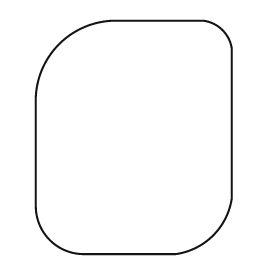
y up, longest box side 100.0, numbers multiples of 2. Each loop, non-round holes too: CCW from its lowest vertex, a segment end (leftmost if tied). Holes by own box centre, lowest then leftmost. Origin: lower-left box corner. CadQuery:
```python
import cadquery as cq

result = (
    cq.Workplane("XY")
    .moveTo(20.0, 0.0)
    .lineTo(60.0, 0.0)
    .threePointArc((76.0, 8.0), (84.0, 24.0))
    .lineTo(84.0, 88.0)
    .threePointArc((80.0, 96.0), (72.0, 100.0))
    .lineTo(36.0, 100.0)
    .threePointArc((10.0, 90.0), (0.0, 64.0))
    .lineTo(0.0, 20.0)
    .threePointArc((6.0, 6.0), (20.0, 0.0))
    .close()
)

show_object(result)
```